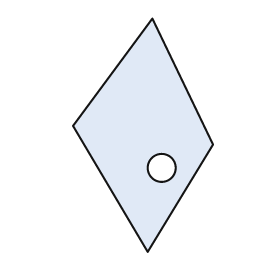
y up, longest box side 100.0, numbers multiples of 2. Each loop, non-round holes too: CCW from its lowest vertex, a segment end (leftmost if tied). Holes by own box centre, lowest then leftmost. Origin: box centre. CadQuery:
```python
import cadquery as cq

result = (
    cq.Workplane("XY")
    .moveTo(2.0, -50.0)
    .lineTo(30.0, -4.0)
    .lineTo(4.0, 50.0)
    .lineTo(-30.0, 4.0)
    .close()
    .moveTo(8.0, -14.0)
    .circle(6.0)
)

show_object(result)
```